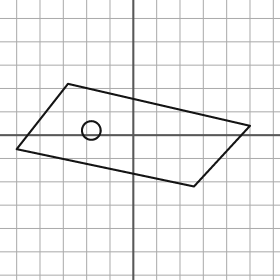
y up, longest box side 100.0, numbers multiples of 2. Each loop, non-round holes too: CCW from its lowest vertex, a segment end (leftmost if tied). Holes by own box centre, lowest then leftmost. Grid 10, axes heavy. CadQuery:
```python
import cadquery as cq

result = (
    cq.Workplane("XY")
    .moveTo(26.0, -22.0)
    .lineTo(50.0, 4.0)
    .lineTo(-28.0, 22.0)
    .lineTo(-50.0, -6.0)
    .close()
    .moveTo(-18.0, 2.0)
    .circle(4.0)
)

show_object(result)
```